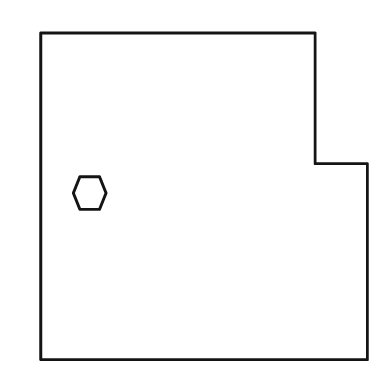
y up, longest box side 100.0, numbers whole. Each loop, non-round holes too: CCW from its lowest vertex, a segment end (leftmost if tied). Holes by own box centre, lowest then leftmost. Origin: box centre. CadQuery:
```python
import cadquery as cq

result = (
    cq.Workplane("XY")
    .moveTo(-50.0, -50.0)
    .lineTo(50.0, -50.0)
    .lineTo(50.0, 10.0)
    .lineTo(34.0, 10.0)
    .lineTo(34.0, 50.0)
    .lineTo(-50.0, 50.0)
    .close()
    .moveTo(-38.0, -4.0)
    .lineTo(-32.0, -4.0)
    .lineTo(-30.0, 1.0)
    .lineTo(-32.0, 6.0)
    .lineTo(-38.0, 6.0)
    .lineTo(-40.0, 1.0)
    .close()
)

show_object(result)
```